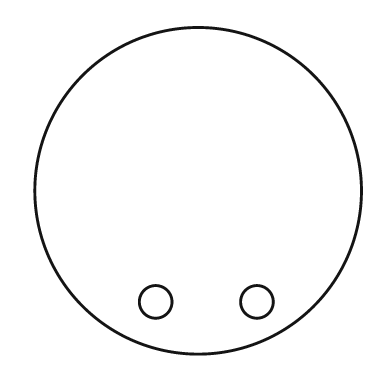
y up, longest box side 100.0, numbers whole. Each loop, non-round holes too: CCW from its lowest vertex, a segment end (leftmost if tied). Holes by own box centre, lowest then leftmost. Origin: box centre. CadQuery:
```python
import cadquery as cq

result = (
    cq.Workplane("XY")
    .moveTo(0.0, 0.0)
    .circle(50.0)
    .moveTo(-13.0, -34.0)
    .circle(5.0)
    .moveTo(18.0, -34.0)
    .circle(5.0)
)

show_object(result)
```